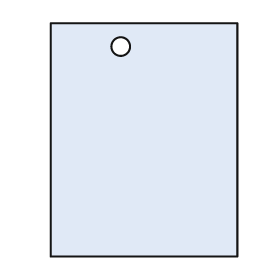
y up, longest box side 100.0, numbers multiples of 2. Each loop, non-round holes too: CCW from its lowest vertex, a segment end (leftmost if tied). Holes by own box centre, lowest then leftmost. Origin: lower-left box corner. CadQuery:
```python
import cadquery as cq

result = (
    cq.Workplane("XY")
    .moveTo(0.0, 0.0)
    .lineTo(80.0, 0.0)
    .lineTo(80.0, 100.0)
    .lineTo(0.0, 100.0)
    .close()
    .moveTo(30.0, 90.0)
    .circle(4.0)
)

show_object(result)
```